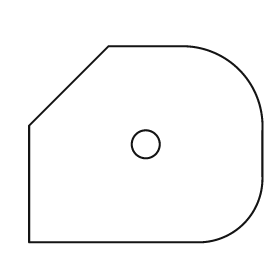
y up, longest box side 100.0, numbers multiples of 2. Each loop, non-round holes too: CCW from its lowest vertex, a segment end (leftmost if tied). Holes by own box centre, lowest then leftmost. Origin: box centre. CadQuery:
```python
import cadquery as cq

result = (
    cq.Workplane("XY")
    .moveTo(-50.0, -42.0)
    .lineTo(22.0, -42.0)
    .threePointArc((42.0, -34.0), (50.0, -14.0))
    .lineTo(50.0, 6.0)
    .threePointArc((40.0, 32.0), (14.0, 42.0))
    .lineTo(-16.0, 42.0)
    .lineTo(-50.0, 8.0)
    .close()
    .moveTo(0.0, 0.0)
    .circle(6.0)
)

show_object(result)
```